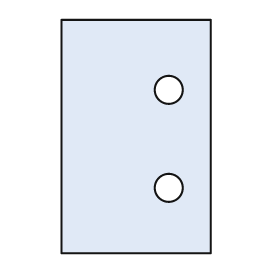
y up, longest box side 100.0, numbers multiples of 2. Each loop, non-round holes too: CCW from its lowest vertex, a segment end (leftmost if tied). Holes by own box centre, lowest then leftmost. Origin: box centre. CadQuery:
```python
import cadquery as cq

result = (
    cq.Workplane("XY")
    .moveTo(-32.0, -50.0)
    .lineTo(32.0, -50.0)
    .lineTo(32.0, 50.0)
    .lineTo(-32.0, 50.0)
    .close()
    .moveTo(14.0, -22.0)
    .circle(6.0)
    .moveTo(14.0, 20.0)
    .circle(6.0)
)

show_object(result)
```